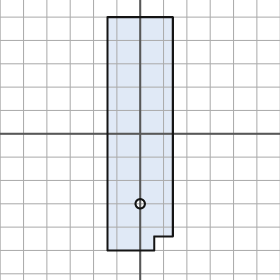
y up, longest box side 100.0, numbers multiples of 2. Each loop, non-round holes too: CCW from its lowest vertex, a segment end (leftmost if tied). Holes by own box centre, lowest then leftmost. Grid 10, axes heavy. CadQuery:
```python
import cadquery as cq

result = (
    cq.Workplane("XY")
    .moveTo(-14.0, -50.0)
    .lineTo(6.0, -50.0)
    .lineTo(6.0, -44.0)
    .lineTo(14.0, -44.0)
    .lineTo(14.0, 50.0)
    .lineTo(-14.0, 50.0)
    .close()
    .moveTo(0.0, -30.0)
    .circle(2.0)
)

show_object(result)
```